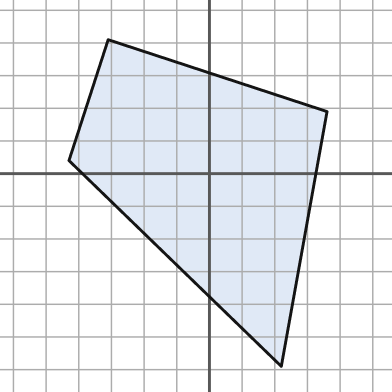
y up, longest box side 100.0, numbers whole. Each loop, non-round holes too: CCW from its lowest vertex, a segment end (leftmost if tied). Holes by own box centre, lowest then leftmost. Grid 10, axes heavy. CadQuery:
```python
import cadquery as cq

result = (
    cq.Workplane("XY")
    .moveTo(22.0, -59.0)
    .lineTo(36.0, 19.0)
    .lineTo(-31.0, 41.0)
    .lineTo(-43.0, 4.0)
    .close()
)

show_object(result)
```